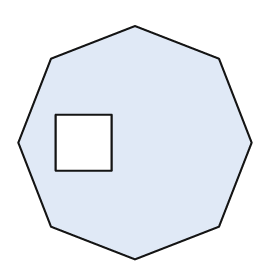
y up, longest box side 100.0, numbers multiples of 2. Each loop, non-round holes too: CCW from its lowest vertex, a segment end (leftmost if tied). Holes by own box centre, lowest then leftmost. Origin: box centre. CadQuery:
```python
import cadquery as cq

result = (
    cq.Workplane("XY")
    .moveTo(0.0, -50.0)
    .lineTo(36.0, -36.0)
    .lineTo(50.0, 0.0)
    .lineTo(36.0, 36.0)
    .lineTo(0.0, 50.0)
    .lineTo(-36.0, 36.0)
    .lineTo(-50.0, 0.0)
    .lineTo(-36.0, -36.0)
    .close()
    .moveTo(-34.0, -12.0)
    .lineTo(-10.0, -12.0)
    .lineTo(-10.0, 12.0)
    .lineTo(-34.0, 12.0)
    .close()
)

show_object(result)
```